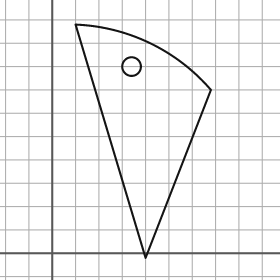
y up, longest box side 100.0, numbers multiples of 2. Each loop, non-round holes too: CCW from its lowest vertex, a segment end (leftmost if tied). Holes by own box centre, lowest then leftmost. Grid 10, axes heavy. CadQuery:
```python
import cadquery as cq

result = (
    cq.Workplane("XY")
    .moveTo(40.0, -2.0)
    .lineTo(68.0, 70.0)
    .threePointArc((42.0, 90.0), (10.0, 98.0))
    .close()
    .moveTo(34.0, 80.0)
    .circle(4.0)
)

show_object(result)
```